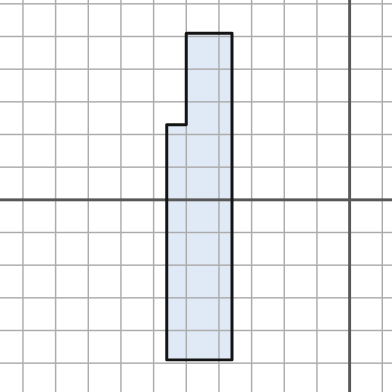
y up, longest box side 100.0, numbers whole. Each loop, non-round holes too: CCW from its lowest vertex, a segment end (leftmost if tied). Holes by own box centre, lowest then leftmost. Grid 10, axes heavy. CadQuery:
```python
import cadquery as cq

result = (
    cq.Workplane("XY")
    .moveTo(-56.0, -49.0)
    .lineTo(-36.0, -49.0)
    .lineTo(-36.0, 51.0)
    .lineTo(-50.0, 51.0)
    .lineTo(-50.0, 23.0)
    .lineTo(-56.0, 23.0)
    .close()
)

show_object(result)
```